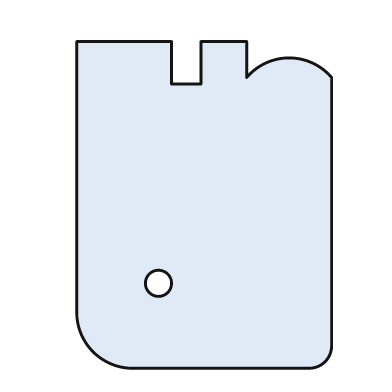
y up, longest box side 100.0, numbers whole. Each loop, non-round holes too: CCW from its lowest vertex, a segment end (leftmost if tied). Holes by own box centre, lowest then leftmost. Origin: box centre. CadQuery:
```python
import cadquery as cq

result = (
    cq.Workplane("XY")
    .moveTo(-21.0, -50.0)
    .lineTo(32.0, -50.0)
    .threePointArc((37.0, -48.0), (39.0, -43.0))
    .lineTo(39.0, 39.0)
    .threePointArc((26.0, 45.0), (13.0, 39.0))
    .lineTo(13.0, 50.0)
    .lineTo(-1.0, 50.0)
    .lineTo(-1.0, 37.0)
    .lineTo(-10.0, 37.0)
    .lineTo(-10.0, 50.0)
    .lineTo(-39.0, 50.0)
    .lineTo(-39.0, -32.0)
    .threePointArc((-34.0, -45.0), (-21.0, -50.0))
    .close()
    .moveTo(-14.0, -24.0)
    .circle(4.0)
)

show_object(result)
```